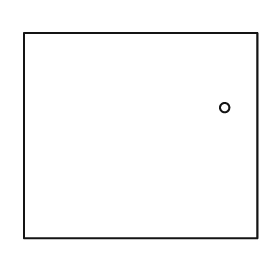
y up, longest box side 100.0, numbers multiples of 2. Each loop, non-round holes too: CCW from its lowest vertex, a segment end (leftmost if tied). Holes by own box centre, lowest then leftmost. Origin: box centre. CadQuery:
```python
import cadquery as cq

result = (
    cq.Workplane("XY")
    .moveTo(-50.0, -44.0)
    .lineTo(50.0, -44.0)
    .lineTo(50.0, 44.0)
    .lineTo(-50.0, 44.0)
    .close()
    .moveTo(36.0, 12.0)
    .circle(2.0)
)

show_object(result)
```